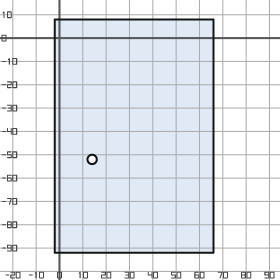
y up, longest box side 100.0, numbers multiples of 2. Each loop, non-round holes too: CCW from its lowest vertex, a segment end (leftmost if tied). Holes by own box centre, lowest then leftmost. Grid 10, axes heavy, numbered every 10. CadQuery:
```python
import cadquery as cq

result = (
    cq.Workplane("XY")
    .moveTo(-2.0, -92.0)
    .lineTo(66.0, -92.0)
    .lineTo(66.0, 8.0)
    .lineTo(-2.0, 8.0)
    .close()
    .moveTo(14.0, -52.0)
    .circle(2.0)
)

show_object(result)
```